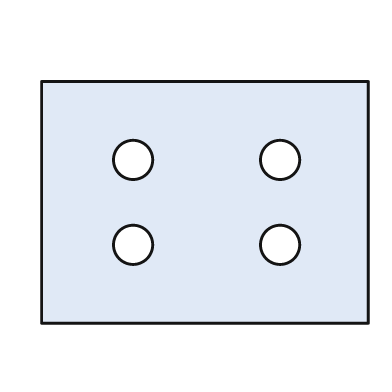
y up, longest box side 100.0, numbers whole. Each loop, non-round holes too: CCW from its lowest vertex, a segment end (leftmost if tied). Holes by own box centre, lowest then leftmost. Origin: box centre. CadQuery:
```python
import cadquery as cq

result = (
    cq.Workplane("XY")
    .moveTo(-50.0, -37.0)
    .lineTo(50.0, -37.0)
    .lineTo(50.0, 37.0)
    .lineTo(-50.0, 37.0)
    .close()
    .moveTo(-22.0, -13.0)
    .circle(6.0)
    .moveTo(23.0, -13.0)
    .circle(6.0)
    .moveTo(-22.0, 13.0)
    .circle(6.0)
    .moveTo(23.0, 13.0)
    .circle(6.0)
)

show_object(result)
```